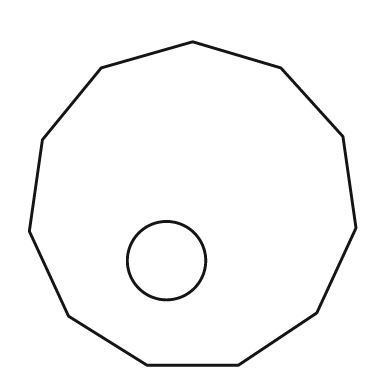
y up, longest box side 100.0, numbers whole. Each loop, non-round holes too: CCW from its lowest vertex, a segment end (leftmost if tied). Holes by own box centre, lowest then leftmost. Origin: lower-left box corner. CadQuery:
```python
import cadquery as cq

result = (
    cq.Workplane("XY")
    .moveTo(36.0, 0.0)
    .lineTo(64.0, 0.0)
    .lineTo(88.0, 16.0)
    .lineTo(100.0, 42.0)
    .lineTo(96.0, 70.0)
    .lineTo(77.0, 91.0)
    .lineTo(50.0, 99.0)
    .lineTo(22.0, 91.0)
    .lineTo(4.0, 69.0)
    .lineTo(0.0, 41.0)
    .lineTo(12.0, 15.0)
    .close()
    .moveTo(42.0, 32.0)
    .circle(12.0)
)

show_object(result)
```